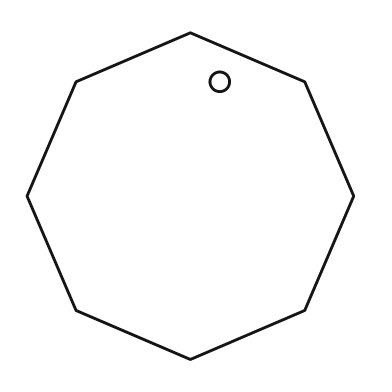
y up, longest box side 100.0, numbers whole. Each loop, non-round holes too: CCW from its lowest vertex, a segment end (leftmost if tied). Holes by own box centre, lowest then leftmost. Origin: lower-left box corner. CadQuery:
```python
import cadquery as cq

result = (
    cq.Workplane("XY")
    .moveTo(50.0, 0.0)
    .lineTo(85.0, 15.0)
    .lineTo(100.0, 50.0)
    .lineTo(85.0, 85.0)
    .lineTo(50.0, 100.0)
    .lineTo(15.0, 85.0)
    .lineTo(0.0, 50.0)
    .lineTo(15.0, 15.0)
    .close()
    .moveTo(59.0, 85.0)
    .circle(3.0)
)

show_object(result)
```